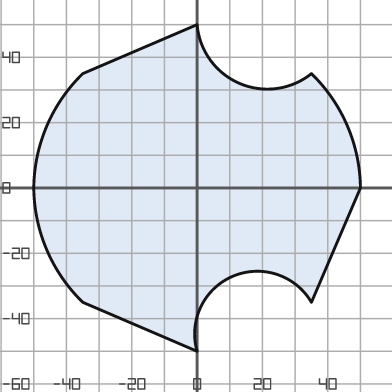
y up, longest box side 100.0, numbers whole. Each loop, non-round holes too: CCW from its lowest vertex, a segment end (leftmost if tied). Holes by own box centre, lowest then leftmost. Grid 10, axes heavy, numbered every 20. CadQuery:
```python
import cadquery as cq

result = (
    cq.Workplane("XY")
    .moveTo(0.0, -50.0)
    .threePointArc((11.0, -27.0), (35.0, -35.0))
    .lineTo(50.0, 0.0)
    .threePointArc((46.0, 19.0), (35.0, 35.0))
    .threePointArc((13.0, 32.0), (0.0, 50.0))
    .lineTo(-35.0, 35.0)
    .threePointArc((-46.0, 19.0), (-50.0, 0.0))
    .threePointArc((-46.0, -19.0), (-35.0, -35.0))
    .close()
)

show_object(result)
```